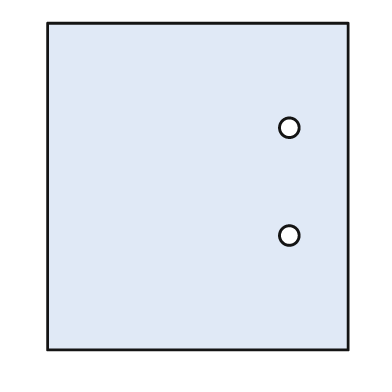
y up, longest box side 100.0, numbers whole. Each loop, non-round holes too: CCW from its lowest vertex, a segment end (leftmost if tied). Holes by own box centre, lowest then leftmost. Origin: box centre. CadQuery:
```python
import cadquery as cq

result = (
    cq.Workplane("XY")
    .moveTo(-46.0, -50.0)
    .lineTo(46.0, -50.0)
    .lineTo(46.0, 50.0)
    .lineTo(-46.0, 50.0)
    .close()
    .moveTo(28.0, -15.0)
    .circle(3.0)
    .moveTo(28.0, 18.0)
    .circle(3.0)
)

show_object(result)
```